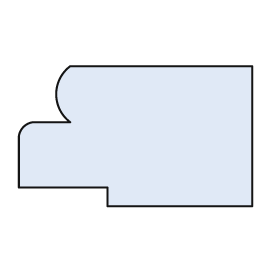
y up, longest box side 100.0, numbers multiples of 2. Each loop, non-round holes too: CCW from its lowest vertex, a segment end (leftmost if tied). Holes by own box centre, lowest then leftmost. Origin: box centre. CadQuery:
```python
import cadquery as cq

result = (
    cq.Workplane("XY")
    .moveTo(-12.0, -30.0)
    .lineTo(50.0, -30.0)
    .lineTo(50.0, 30.0)
    .lineTo(-28.0, 30.0)
    .threePointArc((-34.0, 18.0), (-28.0, 6.0))
    .lineTo(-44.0, 6.0)
    .threePointArc((-48.0, 4.0), (-50.0, 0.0))
    .lineTo(-50.0, -22.0)
    .lineTo(-12.0, -22.0)
    .close()
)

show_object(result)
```